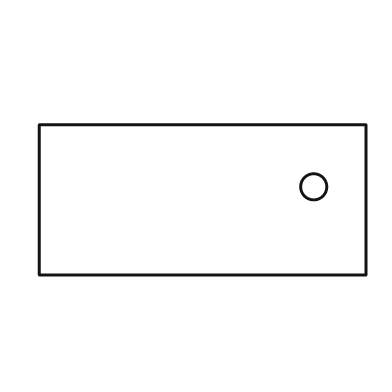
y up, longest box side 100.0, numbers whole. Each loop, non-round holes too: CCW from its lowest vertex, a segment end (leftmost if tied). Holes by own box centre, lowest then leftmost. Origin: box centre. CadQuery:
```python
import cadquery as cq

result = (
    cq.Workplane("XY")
    .moveTo(-50.0, -23.0)
    .lineTo(50.0, -23.0)
    .lineTo(50.0, 23.0)
    .lineTo(-50.0, 23.0)
    .close()
    .moveTo(34.0, 4.0)
    .circle(4.0)
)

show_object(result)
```